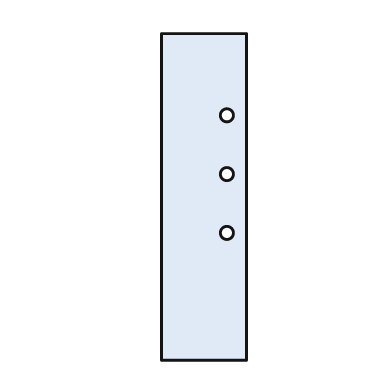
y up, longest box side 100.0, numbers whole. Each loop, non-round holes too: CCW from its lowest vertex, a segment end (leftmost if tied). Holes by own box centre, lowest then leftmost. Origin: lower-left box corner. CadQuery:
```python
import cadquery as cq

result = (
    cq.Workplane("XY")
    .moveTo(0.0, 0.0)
    .lineTo(26.0, 0.0)
    .lineTo(26.0, 100.0)
    .lineTo(0.0, 100.0)
    .close()
    .moveTo(20.0, 39.0)
    .circle(2.0)
    .moveTo(20.0, 57.0)
    .circle(2.0)
    .moveTo(20.0, 75.0)
    .circle(2.0)
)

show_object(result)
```